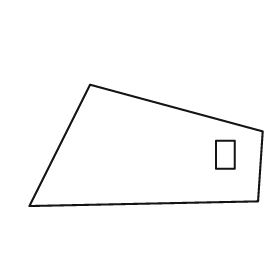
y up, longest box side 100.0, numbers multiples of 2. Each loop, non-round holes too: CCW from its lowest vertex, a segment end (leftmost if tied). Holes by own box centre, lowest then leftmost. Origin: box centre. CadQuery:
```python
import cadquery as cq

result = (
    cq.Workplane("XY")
    .moveTo(-50.0, -26.0)
    .lineTo(48.0, -24.0)
    .lineTo(50.0, 6.0)
    .lineTo(-24.0, 26.0)
    .close()
    .moveTo(30.0, -10.0)
    .lineTo(38.0, -10.0)
    .lineTo(38.0, 2.0)
    .lineTo(30.0, 2.0)
    .close()
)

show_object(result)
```